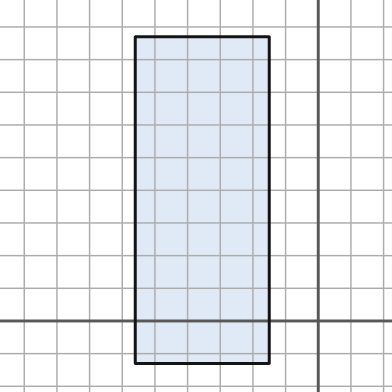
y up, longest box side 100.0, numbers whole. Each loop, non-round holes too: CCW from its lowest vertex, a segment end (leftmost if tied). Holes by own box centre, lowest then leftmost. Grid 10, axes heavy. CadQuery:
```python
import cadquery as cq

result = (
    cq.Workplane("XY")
    .moveTo(-56.0, -13.0)
    .lineTo(-15.0, -13.0)
    .lineTo(-15.0, 87.0)
    .lineTo(-56.0, 87.0)
    .close()
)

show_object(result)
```